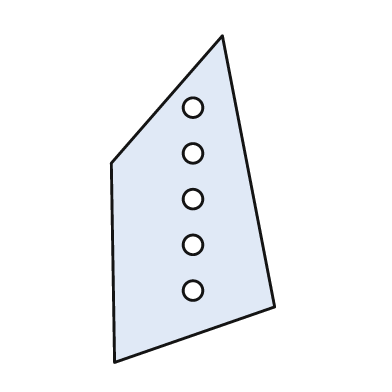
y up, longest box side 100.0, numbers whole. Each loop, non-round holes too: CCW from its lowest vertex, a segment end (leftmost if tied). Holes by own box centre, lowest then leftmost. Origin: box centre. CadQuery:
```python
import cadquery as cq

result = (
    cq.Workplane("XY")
    .moveTo(-24.0, -50.0)
    .lineTo(25.0, -33.0)
    .lineTo(9.0, 50.0)
    .lineTo(-25.0, 11.0)
    .close()
    .moveTo(0.0, -28.0)
    .circle(3.0)
    .moveTo(0.0, -14.0)
    .circle(3.0)
    .moveTo(0.0, 0.0)
    .circle(3.0)
    .moveTo(0.0, 14.0)
    .circle(3.0)
    .moveTo(0.0, 28.0)
    .circle(3.0)
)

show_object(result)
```